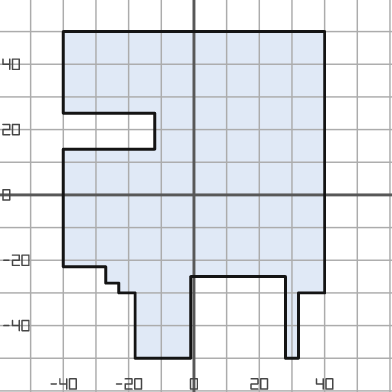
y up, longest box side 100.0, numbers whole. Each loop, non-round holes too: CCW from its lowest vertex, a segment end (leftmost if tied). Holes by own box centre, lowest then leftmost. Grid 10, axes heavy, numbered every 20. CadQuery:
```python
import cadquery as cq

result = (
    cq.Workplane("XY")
    .moveTo(-18.0, -50.0)
    .lineTo(-1.0, -50.0)
    .lineTo(-1.0, -25.0)
    .lineTo(28.0, -25.0)
    .lineTo(28.0, -50.0)
    .lineTo(32.0, -50.0)
    .lineTo(32.0, -30.0)
    .lineTo(40.0, -30.0)
    .lineTo(40.0, 50.0)
    .lineTo(-40.0, 50.0)
    .lineTo(-40.0, 25.0)
    .lineTo(-12.0, 25.0)
    .lineTo(-12.0, 14.0)
    .lineTo(-40.0, 14.0)
    .lineTo(-40.0, -22.0)
    .lineTo(-27.0, -22.0)
    .lineTo(-27.0, -27.0)
    .lineTo(-23.0, -27.0)
    .lineTo(-23.0, -30.0)
    .lineTo(-18.0, -30.0)
    .close()
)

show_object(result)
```